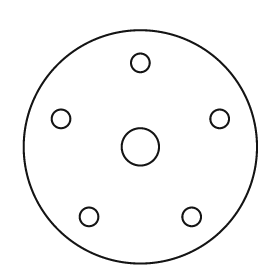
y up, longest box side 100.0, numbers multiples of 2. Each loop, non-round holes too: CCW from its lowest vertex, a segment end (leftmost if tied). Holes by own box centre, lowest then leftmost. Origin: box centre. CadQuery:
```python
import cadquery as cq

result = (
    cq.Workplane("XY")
    .moveTo(0.0, 0.0)
    .circle(50.0)
    .moveTo(-22.0, -30.0)
    .circle(4.0)
    .moveTo(22.0, -30.0)
    .circle(4.0)
    .moveTo(0.0, 0.0)
    .circle(8.0)
    .moveTo(-34.0, 12.0)
    .circle(4.0)
    .moveTo(34.0, 12.0)
    .circle(4.0)
    .moveTo(0.0, 36.0)
    .circle(4.0)
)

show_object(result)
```